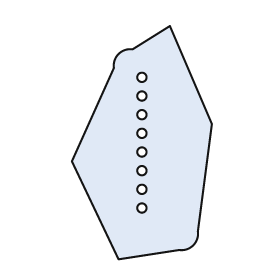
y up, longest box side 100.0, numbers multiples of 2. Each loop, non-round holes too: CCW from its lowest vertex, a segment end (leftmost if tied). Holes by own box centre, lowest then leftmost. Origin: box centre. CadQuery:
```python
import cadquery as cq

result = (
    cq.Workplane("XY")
    .moveTo(-10.0, -50.0)
    .lineTo(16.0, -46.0)
    .threePointArc((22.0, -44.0), (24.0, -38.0))
    .lineTo(30.0, 8.0)
    .lineTo(12.0, 50.0)
    .lineTo(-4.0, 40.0)
    .threePointArc((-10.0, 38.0), (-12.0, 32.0))
    .lineTo(-30.0, -8.0)
    .close()
    .moveTo(0.0, -28.0)
    .circle(2.0)
    .moveTo(0.0, -20.0)
    .circle(2.0)
    .moveTo(0.0, -12.0)
    .circle(2.0)
    .moveTo(0.0, -4.0)
    .circle(2.0)
    .moveTo(0.0, 4.0)
    .circle(2.0)
    .moveTo(0.0, 12.0)
    .circle(2.0)
    .moveTo(0.0, 20.0)
    .circle(2.0)
    .moveTo(0.0, 28.0)
    .circle(2.0)
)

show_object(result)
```